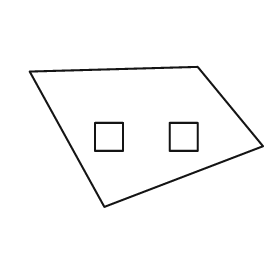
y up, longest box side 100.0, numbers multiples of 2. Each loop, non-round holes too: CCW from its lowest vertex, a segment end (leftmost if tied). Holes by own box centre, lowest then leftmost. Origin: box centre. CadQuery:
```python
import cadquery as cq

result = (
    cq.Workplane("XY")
    .moveTo(-18.0, -30.0)
    .lineTo(50.0, -4.0)
    .lineTo(22.0, 30.0)
    .lineTo(-50.0, 28.0)
    .close()
    .moveTo(-22.0, -6.0)
    .lineTo(-10.0, -6.0)
    .lineTo(-10.0, 6.0)
    .lineTo(-22.0, 6.0)
    .close()
    .moveTo(10.0, -6.0)
    .lineTo(22.0, -6.0)
    .lineTo(22.0, 6.0)
    .lineTo(10.0, 6.0)
    .close()
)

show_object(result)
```